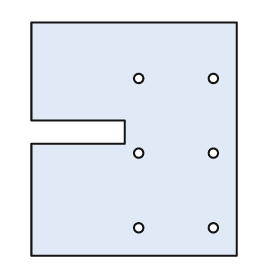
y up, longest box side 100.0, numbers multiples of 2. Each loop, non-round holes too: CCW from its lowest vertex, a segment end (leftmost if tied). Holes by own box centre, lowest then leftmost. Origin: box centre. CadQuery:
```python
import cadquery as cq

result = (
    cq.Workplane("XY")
    .moveTo(-44.0, -50.0)
    .lineTo(44.0, -50.0)
    .lineTo(44.0, 50.0)
    .lineTo(-44.0, 50.0)
    .lineTo(-44.0, 8.0)
    .lineTo(-4.0, 8.0)
    .lineTo(-4.0, -2.0)
    .lineTo(-44.0, -2.0)
    .close()
    .moveTo(2.0, -38.0)
    .circle(2.0)
    .moveTo(34.0, -38.0)
    .circle(2.0)
    .moveTo(2.0, -6.0)
    .circle(2.0)
    .moveTo(34.0, -6.0)
    .circle(2.0)
    .moveTo(2.0, 26.0)
    .circle(2.0)
    .moveTo(34.0, 26.0)
    .circle(2.0)
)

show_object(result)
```